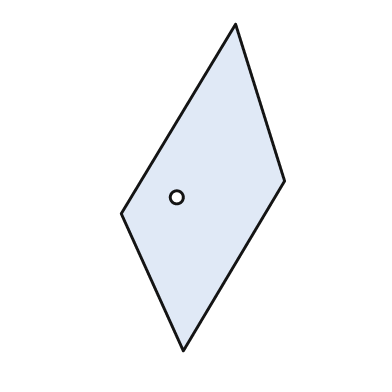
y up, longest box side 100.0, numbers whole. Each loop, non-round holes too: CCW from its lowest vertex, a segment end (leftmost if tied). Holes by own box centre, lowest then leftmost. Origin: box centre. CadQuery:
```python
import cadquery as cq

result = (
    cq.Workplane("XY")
    .moveTo(-6.0, -50.0)
    .lineTo(25.0, 2.0)
    .lineTo(10.0, 50.0)
    .lineTo(-25.0, -8.0)
    .close()
    .moveTo(-8.0, -3.0)
    .circle(2.0)
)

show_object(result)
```